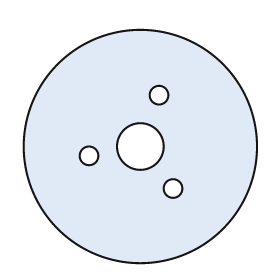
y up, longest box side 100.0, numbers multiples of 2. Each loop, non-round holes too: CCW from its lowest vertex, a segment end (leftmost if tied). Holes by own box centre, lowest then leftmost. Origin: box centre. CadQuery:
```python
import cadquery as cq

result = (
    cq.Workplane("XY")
    .moveTo(0.0, 0.0)
    .circle(50.0)
    .moveTo(14.0, -18.0)
    .circle(4.0)
    .moveTo(-22.0, -4.0)
    .circle(4.0)
    .moveTo(0.0, 0.0)
    .circle(10.0)
    .moveTo(8.0, 22.0)
    .circle(4.0)
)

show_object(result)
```